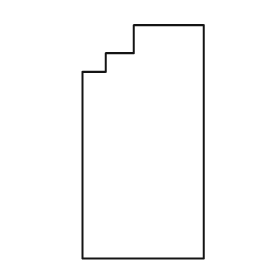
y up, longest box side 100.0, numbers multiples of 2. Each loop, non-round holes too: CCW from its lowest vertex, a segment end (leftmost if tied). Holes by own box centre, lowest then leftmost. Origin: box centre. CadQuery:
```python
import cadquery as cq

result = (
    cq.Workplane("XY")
    .moveTo(-26.0, -50.0)
    .lineTo(26.0, -50.0)
    .lineTo(26.0, 50.0)
    .lineTo(-4.0, 50.0)
    .lineTo(-4.0, 38.0)
    .lineTo(-16.0, 38.0)
    .lineTo(-16.0, 30.0)
    .lineTo(-26.0, 30.0)
    .close()
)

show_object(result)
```